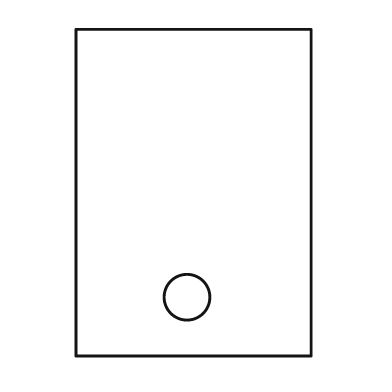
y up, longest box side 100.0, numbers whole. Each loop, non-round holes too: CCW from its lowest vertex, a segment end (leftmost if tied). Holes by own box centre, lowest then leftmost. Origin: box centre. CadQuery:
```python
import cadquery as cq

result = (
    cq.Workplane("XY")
    .moveTo(-36.0, -50.0)
    .lineTo(36.0, -50.0)
    .lineTo(36.0, 50.0)
    .lineTo(-36.0, 50.0)
    .close()
    .moveTo(-2.0, -32.0)
    .circle(7.0)
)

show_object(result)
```